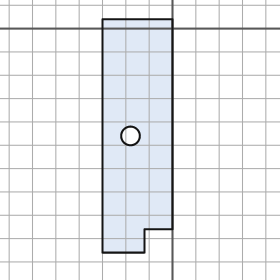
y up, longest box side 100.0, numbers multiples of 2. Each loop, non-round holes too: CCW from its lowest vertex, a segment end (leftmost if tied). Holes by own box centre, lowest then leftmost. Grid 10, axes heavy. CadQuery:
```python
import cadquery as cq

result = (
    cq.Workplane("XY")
    .moveTo(-30.0, -96.0)
    .lineTo(-12.0, -96.0)
    .lineTo(-12.0, -86.0)
    .lineTo(0.0, -86.0)
    .lineTo(0.0, 4.0)
    .lineTo(-30.0, 4.0)
    .close()
    .moveTo(-18.0, -46.0)
    .circle(4.0)
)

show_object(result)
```